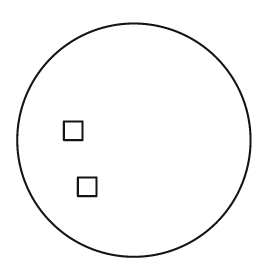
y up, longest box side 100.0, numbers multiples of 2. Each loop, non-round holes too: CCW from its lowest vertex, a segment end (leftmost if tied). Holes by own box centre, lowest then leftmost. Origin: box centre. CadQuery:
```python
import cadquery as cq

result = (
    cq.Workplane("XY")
    .moveTo(0.0, 0.0)
    .circle(50.0)
    .moveTo(-24.0, -24.0)
    .lineTo(-16.0, -24.0)
    .lineTo(-16.0, -16.0)
    .lineTo(-24.0, -16.0)
    .close()
    .moveTo(-30.0, 0.0)
    .lineTo(-22.0, 0.0)
    .lineTo(-22.0, 8.0)
    .lineTo(-30.0, 8.0)
    .close()
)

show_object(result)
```